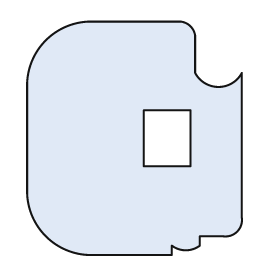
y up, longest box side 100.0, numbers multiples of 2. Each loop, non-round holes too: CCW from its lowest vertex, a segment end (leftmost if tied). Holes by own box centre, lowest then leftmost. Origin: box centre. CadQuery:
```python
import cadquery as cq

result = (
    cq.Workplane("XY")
    .moveTo(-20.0, -50.0)
    .lineTo(16.0, -50.0)
    .lineTo(16.0, -46.0)
    .threePointArc((22.0, -48.0), (28.0, -46.0))
    .lineTo(28.0, -42.0)
    .lineTo(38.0, -42.0)
    .threePointArc((44.0, -40.0), (46.0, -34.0))
    .lineTo(46.0, 28.0)
    .threePointArc((36.0, 22.0), (26.0, 28.0))
    .lineTo(26.0, 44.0)
    .threePointArc((24.0, 48.0), (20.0, 50.0))
    .lineTo(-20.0, 50.0)
    .threePointArc((-38.0, 42.0), (-46.0, 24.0))
    .lineTo(-46.0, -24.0)
    .threePointArc((-38.0, -42.0), (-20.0, -50.0))
    .close()
    .moveTo(4.0, -12.0)
    .lineTo(24.0, -12.0)
    .lineTo(24.0, 12.0)
    .lineTo(4.0, 12.0)
    .close()
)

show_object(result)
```